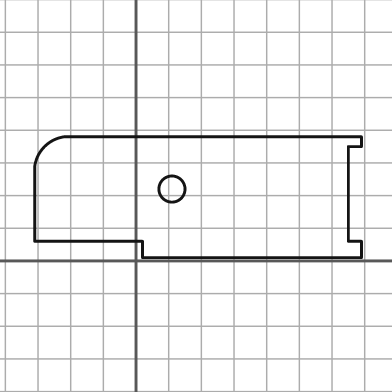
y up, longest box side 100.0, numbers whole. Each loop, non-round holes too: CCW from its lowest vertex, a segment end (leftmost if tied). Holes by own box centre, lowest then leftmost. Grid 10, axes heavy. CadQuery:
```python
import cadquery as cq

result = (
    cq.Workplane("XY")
    .moveTo(2.0, 1.0)
    .lineTo(69.0, 1.0)
    .lineTo(69.0, 6.0)
    .lineTo(65.0, 6.0)
    .lineTo(65.0, 35.0)
    .lineTo(69.0, 35.0)
    .lineTo(69.0, 38.0)
    .lineTo(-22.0, 38.0)
    .threePointArc((-28.0, 35.0), (-31.0, 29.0))
    .lineTo(-31.0, 6.0)
    .lineTo(2.0, 6.0)
    .close()
    .moveTo(11.0, 22.0)
    .circle(4.0)
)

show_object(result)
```